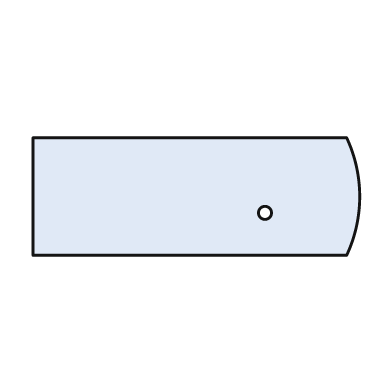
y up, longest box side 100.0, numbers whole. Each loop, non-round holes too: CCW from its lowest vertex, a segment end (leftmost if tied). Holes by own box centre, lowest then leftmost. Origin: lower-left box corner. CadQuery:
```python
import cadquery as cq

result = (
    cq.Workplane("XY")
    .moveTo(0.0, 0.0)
    .lineTo(96.0, 0.0)
    .threePointArc((100.0, 18.0), (96.0, 36.0))
    .lineTo(0.0, 36.0)
    .close()
    .moveTo(71.0, 13.0)
    .circle(2.0)
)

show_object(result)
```